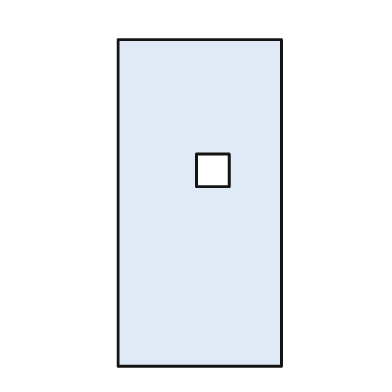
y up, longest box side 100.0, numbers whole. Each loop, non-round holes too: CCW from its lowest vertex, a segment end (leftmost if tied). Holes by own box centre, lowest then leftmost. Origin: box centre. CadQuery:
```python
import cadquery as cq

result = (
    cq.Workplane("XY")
    .moveTo(-25.0, -50.0)
    .lineTo(25.0, -50.0)
    .lineTo(25.0, 50.0)
    .lineTo(-25.0, 50.0)
    .close()
    .moveTo(-1.0, 5.0)
    .lineTo(9.0, 5.0)
    .lineTo(9.0, 15.0)
    .lineTo(-1.0, 15.0)
    .close()
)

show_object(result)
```